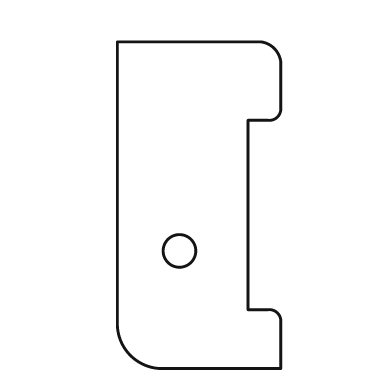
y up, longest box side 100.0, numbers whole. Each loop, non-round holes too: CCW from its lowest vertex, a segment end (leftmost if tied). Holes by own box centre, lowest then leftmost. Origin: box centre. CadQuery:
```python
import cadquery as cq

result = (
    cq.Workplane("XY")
    .moveTo(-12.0, -50.0)
    .lineTo(25.0, -50.0)
    .lineTo(25.0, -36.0)
    .threePointArc((24.0, -33.0), (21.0, -32.0))
    .lineTo(15.0, -32.0)
    .lineTo(15.0, 26.0)
    .lineTo(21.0, 26.0)
    .threePointArc((24.0, 27.0), (25.0, 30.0))
    .lineTo(25.0, 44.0)
    .threePointArc((23.0, 48.0), (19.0, 50.0))
    .lineTo(-25.0, 50.0)
    .lineTo(-25.0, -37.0)
    .threePointArc((-21.0, -46.0), (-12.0, -50.0))
    .close()
    .moveTo(-6.0, -14.0)
    .circle(5.0)
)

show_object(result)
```